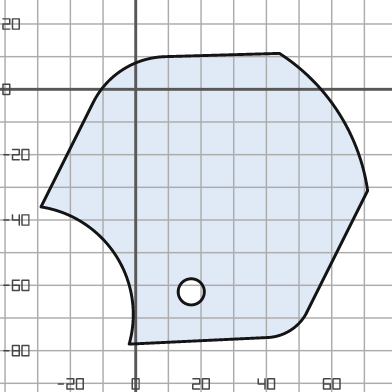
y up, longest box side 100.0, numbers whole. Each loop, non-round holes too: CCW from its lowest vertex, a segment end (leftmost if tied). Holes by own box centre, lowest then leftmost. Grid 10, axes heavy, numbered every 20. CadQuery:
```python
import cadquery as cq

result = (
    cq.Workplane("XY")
    .moveTo(-2.0, -78.0)
    .lineTo(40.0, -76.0)
    .threePointArc((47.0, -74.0), (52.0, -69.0))
    .lineTo(71.0, -31.0)
    .threePointArc((62.0, -7.0), (44.0, 11.0))
    .lineTo(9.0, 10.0)
    .threePointArc((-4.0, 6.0), (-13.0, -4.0))
    .lineTo(-29.0, -36.0)
    .threePointArc((-6.0, -51.0), (-2.0, -78.0))
    .close()
    .moveTo(17.0, -62.0)
    .circle(4.0)
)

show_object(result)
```